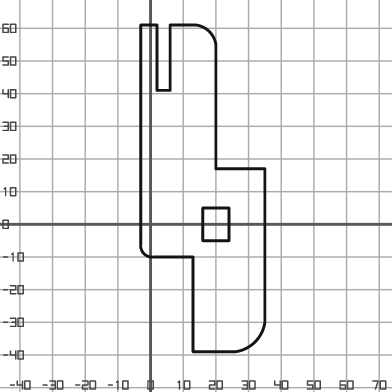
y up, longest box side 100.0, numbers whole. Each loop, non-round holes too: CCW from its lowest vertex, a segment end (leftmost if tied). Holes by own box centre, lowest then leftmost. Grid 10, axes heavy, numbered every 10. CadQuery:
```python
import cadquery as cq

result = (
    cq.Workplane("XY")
    .moveTo(13.0, -39.0)
    .lineTo(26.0, -39.0)
    .threePointArc((32.0, -36.0), (35.0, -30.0))
    .lineTo(35.0, 17.0)
    .lineTo(20.0, 17.0)
    .lineTo(20.0, 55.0)
    .threePointArc((18.0, 59.0), (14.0, 61.0))
    .lineTo(6.0, 61.0)
    .lineTo(6.0, 41.0)
    .lineTo(2.0, 41.0)
    .lineTo(2.0, 61.0)
    .lineTo(-3.0, 61.0)
    .lineTo(-3.0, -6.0)
    .threePointArc((-2.0, -9.0), (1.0, -10.0))
    .lineTo(13.0, -10.0)
    .close()
    .moveTo(16.0, -5.0)
    .lineTo(24.0, -5.0)
    .lineTo(24.0, 5.0)
    .lineTo(16.0, 5.0)
    .close()
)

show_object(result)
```